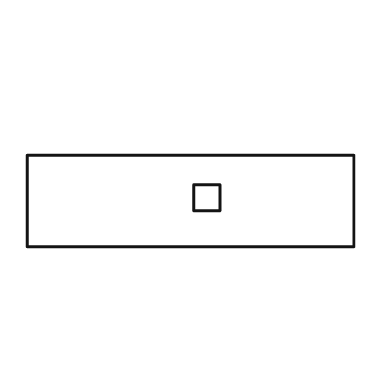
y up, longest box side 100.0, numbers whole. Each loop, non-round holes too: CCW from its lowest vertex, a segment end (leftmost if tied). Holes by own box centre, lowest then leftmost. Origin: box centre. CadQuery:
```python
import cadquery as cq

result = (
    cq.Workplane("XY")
    .moveTo(-50.0, -14.0)
    .lineTo(50.0, -14.0)
    .lineTo(50.0, 14.0)
    .lineTo(-50.0, 14.0)
    .close()
    .moveTo(1.0, -3.0)
    .lineTo(9.0, -3.0)
    .lineTo(9.0, 5.0)
    .lineTo(1.0, 5.0)
    .close()
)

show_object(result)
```